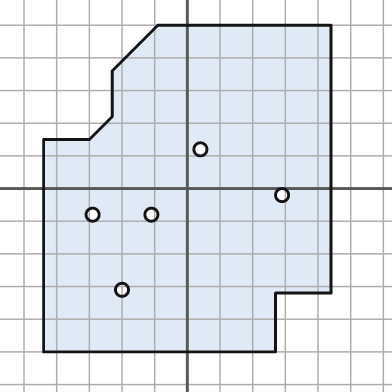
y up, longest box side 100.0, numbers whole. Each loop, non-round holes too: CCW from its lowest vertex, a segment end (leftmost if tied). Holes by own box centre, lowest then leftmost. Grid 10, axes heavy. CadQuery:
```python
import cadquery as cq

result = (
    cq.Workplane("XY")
    .moveTo(-44.0, -50.0)
    .lineTo(27.0, -50.0)
    .lineTo(27.0, -32.0)
    .lineTo(44.0, -32.0)
    .lineTo(44.0, 50.0)
    .lineTo(-9.0, 50.0)
    .lineTo(-23.0, 36.0)
    .lineTo(-23.0, 22.0)
    .lineTo(-30.0, 15.0)
    .lineTo(-44.0, 15.0)
    .close()
    .moveTo(-20.0, -31.0)
    .circle(2.0)
    .moveTo(-29.0, -8.0)
    .circle(2.0)
    .moveTo(-11.0, -8.0)
    .circle(2.0)
    .moveTo(29.0, -2.0)
    .circle(2.0)
    .moveTo(4.0, 12.0)
    .circle(2.0)
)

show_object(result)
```